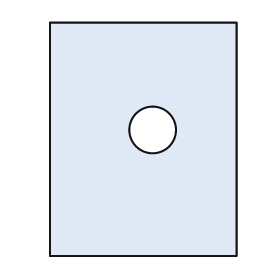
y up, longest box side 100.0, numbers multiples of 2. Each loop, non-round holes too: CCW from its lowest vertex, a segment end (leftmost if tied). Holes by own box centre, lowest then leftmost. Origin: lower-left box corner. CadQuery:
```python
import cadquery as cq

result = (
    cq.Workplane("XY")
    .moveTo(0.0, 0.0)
    .lineTo(80.0, 0.0)
    .lineTo(80.0, 100.0)
    .lineTo(0.0, 100.0)
    .close()
    .moveTo(44.0, 54.0)
    .circle(10.0)
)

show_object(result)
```